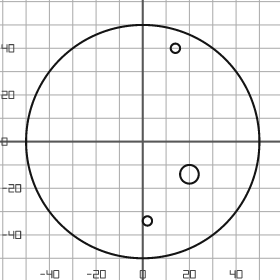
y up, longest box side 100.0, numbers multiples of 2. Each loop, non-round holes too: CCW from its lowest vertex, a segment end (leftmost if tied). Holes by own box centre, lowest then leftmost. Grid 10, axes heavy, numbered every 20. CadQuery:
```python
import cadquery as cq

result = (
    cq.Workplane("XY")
    .moveTo(0.0, 0.0)
    .circle(50.0)
    .moveTo(2.0, -34.0)
    .circle(2.0)
    .moveTo(20.0, -14.0)
    .circle(4.0)
    .moveTo(14.0, 40.0)
    .circle(2.0)
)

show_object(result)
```